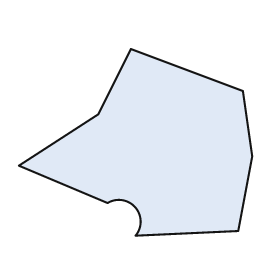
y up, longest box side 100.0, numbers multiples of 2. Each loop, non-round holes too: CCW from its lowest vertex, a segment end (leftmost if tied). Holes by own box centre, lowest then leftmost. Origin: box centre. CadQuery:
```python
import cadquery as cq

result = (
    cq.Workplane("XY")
    .moveTo(0.0, -40.0)
    .lineTo(44.0, -38.0)
    .lineTo(50.0, -6.0)
    .lineTo(46.0, 22.0)
    .lineTo(-2.0, 40.0)
    .lineTo(-16.0, 12.0)
    .lineTo(-50.0, -10.0)
    .lineTo(-12.0, -26.0)
    .threePointArc((0.0, -28.0), (0.0, -40.0))
    .close()
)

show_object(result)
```